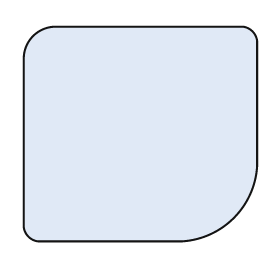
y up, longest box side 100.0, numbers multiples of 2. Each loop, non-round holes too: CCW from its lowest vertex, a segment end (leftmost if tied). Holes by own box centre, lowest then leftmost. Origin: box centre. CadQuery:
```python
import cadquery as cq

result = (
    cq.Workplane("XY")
    .moveTo(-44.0, -46.0)
    .lineTo(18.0, -46.0)
    .threePointArc((40.0, -36.0), (50.0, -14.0))
    .lineTo(50.0, 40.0)
    .threePointArc((48.0, 44.0), (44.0, 46.0))
    .lineTo(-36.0, 46.0)
    .threePointArc((-46.0, 42.0), (-50.0, 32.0))
    .lineTo(-50.0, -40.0)
    .threePointArc((-48.0, -44.0), (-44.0, -46.0))
    .close()
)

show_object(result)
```